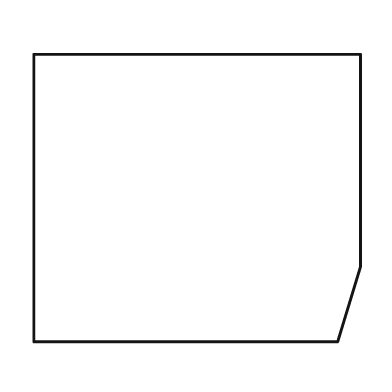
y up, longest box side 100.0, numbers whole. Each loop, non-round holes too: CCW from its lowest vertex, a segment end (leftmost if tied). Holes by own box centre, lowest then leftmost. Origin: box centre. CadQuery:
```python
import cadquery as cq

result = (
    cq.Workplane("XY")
    .moveTo(-50.0, -44.0)
    .lineTo(43.0, -44.0)
    .lineTo(50.0, -21.0)
    .lineTo(50.0, 44.0)
    .lineTo(-50.0, 44.0)
    .close()
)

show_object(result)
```